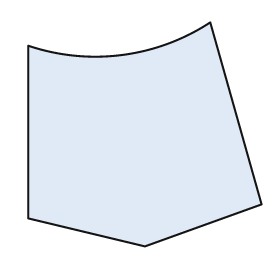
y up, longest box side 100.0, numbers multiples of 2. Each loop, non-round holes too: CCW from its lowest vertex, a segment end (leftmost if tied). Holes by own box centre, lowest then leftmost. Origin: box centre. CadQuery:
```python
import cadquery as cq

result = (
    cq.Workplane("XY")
    .moveTo(0.0, -48.0)
    .lineTo(50.0, -30.0)
    .lineTo(28.0, 48.0)
    .threePointArc((-10.0, 34.0), (-50.0, 38.0))
    .lineTo(-50.0, -36.0)
    .close()
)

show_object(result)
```